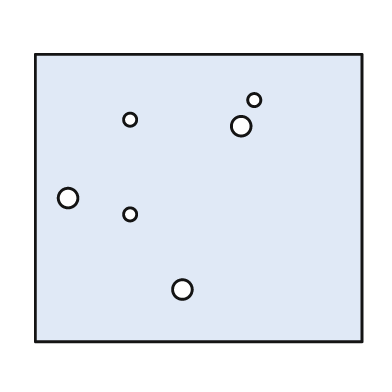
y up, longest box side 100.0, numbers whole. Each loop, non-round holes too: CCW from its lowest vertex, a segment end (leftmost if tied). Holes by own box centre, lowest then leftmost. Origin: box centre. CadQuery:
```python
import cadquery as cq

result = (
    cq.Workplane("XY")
    .moveTo(-50.0, -44.0)
    .lineTo(50.0, -44.0)
    .lineTo(50.0, 44.0)
    .lineTo(-50.0, 44.0)
    .close()
    .moveTo(-5.0, -28.0)
    .circle(3.0)
    .moveTo(-21.0, -5.0)
    .circle(2.0)
    .moveTo(-40.0, 0.0)
    .circle(3.0)
    .moveTo(13.0, 22.0)
    .circle(3.0)
    .moveTo(-21.0, 24.0)
    .circle(2.0)
    .moveTo(17.0, 30.0)
    .circle(2.0)
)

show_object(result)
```